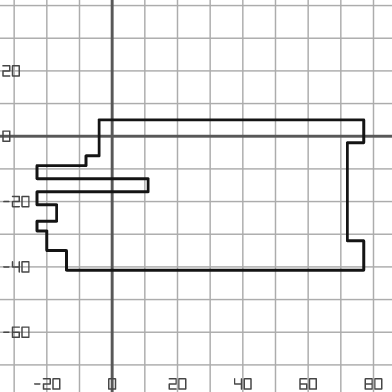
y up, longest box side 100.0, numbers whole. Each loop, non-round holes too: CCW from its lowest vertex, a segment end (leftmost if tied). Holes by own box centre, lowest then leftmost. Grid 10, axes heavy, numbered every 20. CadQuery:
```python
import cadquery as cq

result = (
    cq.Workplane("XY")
    .moveTo(-14.0, -41.0)
    .lineTo(77.0, -41.0)
    .lineTo(77.0, -32.0)
    .lineTo(72.0, -32.0)
    .lineTo(72.0, -2.0)
    .lineTo(77.0, -2.0)
    .lineTo(77.0, 5.0)
    .lineTo(-4.0, 5.0)
    .lineTo(-4.0, -6.0)
    .lineTo(-8.0, -6.0)
    .lineTo(-8.0, -9.0)
    .lineTo(-23.0, -9.0)
    .lineTo(-23.0, -13.0)
    .lineTo(11.0, -13.0)
    .lineTo(11.0, -17.0)
    .lineTo(-23.0, -17.0)
    .lineTo(-23.0, -21.0)
    .lineTo(-17.0, -21.0)
    .lineTo(-17.0, -26.0)
    .lineTo(-23.0, -26.0)
    .lineTo(-23.0, -29.0)
    .lineTo(-20.0, -29.0)
    .lineTo(-20.0, -35.0)
    .lineTo(-14.0, -35.0)
    .close()
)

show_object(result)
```